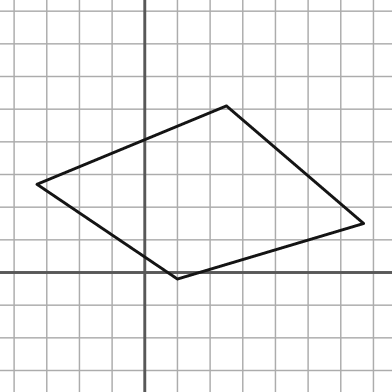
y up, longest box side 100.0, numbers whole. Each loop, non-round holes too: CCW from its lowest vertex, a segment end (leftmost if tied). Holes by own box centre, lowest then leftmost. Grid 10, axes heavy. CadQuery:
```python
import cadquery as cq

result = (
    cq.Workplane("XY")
    .moveTo(10.0, -2.0)
    .lineTo(67.0, 15.0)
    .lineTo(25.0, 51.0)
    .lineTo(-33.0, 27.0)
    .close()
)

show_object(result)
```